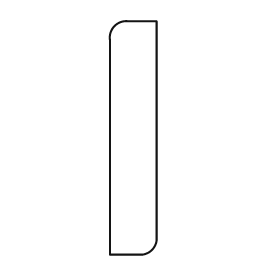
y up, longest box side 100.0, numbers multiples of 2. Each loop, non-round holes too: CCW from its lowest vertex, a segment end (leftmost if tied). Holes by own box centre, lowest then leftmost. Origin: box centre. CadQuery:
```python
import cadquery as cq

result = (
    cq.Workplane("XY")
    .moveTo(-10.0, -50.0)
    .lineTo(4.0, -50.0)
    .threePointArc((8.0, -48.0), (10.0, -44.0))
    .lineTo(10.0, 50.0)
    .lineTo(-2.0, 50.0)
    .threePointArc((-8.0, 48.0), (-10.0, 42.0))
    .close()
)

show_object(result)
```